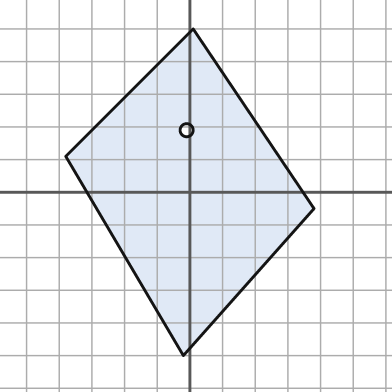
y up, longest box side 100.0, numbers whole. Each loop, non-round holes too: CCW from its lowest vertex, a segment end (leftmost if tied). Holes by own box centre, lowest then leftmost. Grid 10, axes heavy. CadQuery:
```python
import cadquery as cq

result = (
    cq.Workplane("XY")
    .moveTo(-2.0, -50.0)
    .lineTo(38.0, -5.0)
    .lineTo(1.0, 50.0)
    .lineTo(-38.0, 11.0)
    .close()
    .moveTo(-1.0, 19.0)
    .circle(2.0)
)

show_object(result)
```